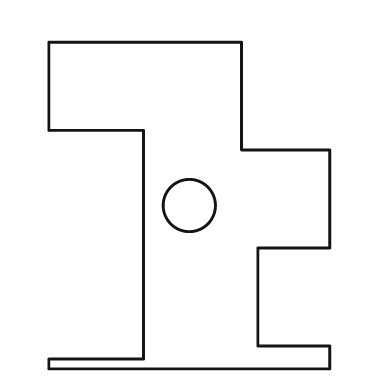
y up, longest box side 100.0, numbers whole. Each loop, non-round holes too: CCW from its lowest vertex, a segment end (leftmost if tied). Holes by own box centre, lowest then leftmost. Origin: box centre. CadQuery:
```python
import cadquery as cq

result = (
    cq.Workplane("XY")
    .moveTo(-43.0, -50.0)
    .lineTo(43.0, -50.0)
    .lineTo(43.0, -43.0)
    .lineTo(21.0, -43.0)
    .lineTo(21.0, -13.0)
    .lineTo(43.0, -13.0)
    .lineTo(43.0, 17.0)
    .lineTo(16.0, 17.0)
    .lineTo(16.0, 50.0)
    .lineTo(-43.0, 50.0)
    .lineTo(-43.0, 23.0)
    .lineTo(-14.0, 23.0)
    .lineTo(-14.0, -47.0)
    .lineTo(-43.0, -47.0)
    .close()
    .moveTo(0.0, 0.0)
    .circle(8.0)
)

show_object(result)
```